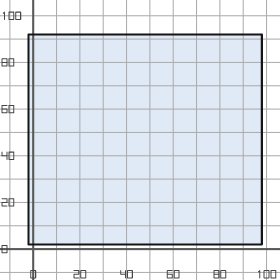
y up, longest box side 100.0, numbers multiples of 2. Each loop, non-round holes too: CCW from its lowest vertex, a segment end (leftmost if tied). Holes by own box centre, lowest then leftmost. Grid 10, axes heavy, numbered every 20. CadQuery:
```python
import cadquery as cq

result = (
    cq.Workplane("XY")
    .moveTo(-2.0, 2.0)
    .lineTo(98.0, 2.0)
    .lineTo(98.0, 92.0)
    .lineTo(-2.0, 92.0)
    .close()
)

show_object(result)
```